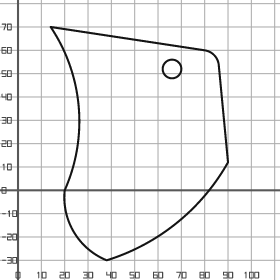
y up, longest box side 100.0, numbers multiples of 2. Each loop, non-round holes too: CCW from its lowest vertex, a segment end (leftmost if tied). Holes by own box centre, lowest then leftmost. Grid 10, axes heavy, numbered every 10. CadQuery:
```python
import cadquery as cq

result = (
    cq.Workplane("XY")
    .moveTo(38.0, -30.0)
    .threePointArc((68.0, -14.0), (90.0, 12.0))
    .lineTo(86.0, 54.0)
    .threePointArc((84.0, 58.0), (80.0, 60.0))
    .lineTo(14.0, 70.0)
    .threePointArc((26.0, 36.0), (20.0, 0.0))
    .threePointArc((24.0, -18.0), (38.0, -30.0))
    .close()
    .moveTo(66.0, 52.0)
    .circle(4.0)
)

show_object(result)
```